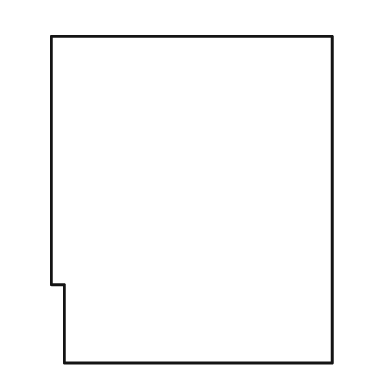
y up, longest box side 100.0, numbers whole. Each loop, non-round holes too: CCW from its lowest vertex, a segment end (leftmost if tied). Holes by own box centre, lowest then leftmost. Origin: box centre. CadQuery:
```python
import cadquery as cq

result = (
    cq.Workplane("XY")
    .moveTo(-39.0, -50.0)
    .lineTo(43.0, -50.0)
    .lineTo(43.0, 50.0)
    .lineTo(-43.0, 50.0)
    .lineTo(-43.0, -26.0)
    .lineTo(-39.0, -26.0)
    .close()
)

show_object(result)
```